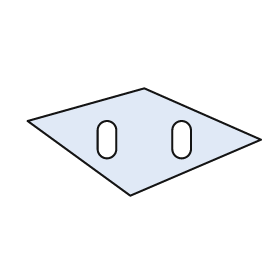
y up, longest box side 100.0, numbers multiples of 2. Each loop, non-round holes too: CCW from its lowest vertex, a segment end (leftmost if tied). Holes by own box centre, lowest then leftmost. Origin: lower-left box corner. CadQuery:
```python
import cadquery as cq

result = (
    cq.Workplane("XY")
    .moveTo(44.0, 0.0)
    .lineTo(100.0, 24.0)
    .lineTo(50.0, 46.0)
    .lineTo(0.0, 32.0)
    .close()
    .moveTo(30.0, 20.0)
    .threePointArc((34.0, 16.0), (38.0, 20.0))
    .lineTo(38.0, 28.0)
    .threePointArc((34.0, 32.0), (30.0, 28.0))
    .close()
    .moveTo(62.0, 20.0)
    .threePointArc((66.0, 16.0), (70.0, 20.0))
    .lineTo(70.0, 28.0)
    .threePointArc((66.0, 32.0), (62.0, 28.0))
    .close()
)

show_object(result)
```